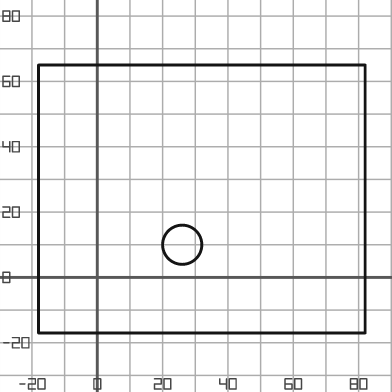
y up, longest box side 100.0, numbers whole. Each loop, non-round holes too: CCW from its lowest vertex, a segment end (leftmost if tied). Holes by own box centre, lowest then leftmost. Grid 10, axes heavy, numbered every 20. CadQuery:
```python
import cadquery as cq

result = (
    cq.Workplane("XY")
    .moveTo(-18.0, -17.0)
    .lineTo(82.0, -17.0)
    .lineTo(82.0, 65.0)
    .lineTo(-18.0, 65.0)
    .close()
    .moveTo(26.0, 10.0)
    .circle(6.0)
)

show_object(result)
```